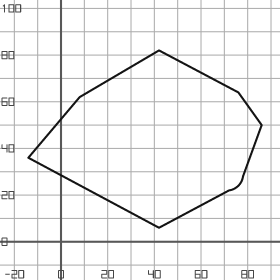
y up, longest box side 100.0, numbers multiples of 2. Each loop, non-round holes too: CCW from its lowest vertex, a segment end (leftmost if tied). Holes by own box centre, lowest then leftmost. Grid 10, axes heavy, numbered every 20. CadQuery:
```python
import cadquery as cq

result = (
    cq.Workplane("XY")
    .moveTo(42.0, 6.0)
    .lineTo(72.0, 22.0)
    .threePointArc((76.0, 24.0), (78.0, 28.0))
    .lineTo(86.0, 50.0)
    .lineTo(76.0, 64.0)
    .lineTo(42.0, 82.0)
    .lineTo(8.0, 62.0)
    .lineTo(-14.0, 36.0)
    .close()
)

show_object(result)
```